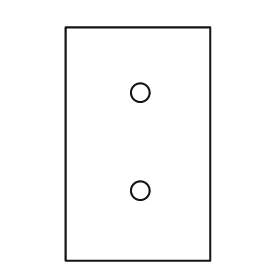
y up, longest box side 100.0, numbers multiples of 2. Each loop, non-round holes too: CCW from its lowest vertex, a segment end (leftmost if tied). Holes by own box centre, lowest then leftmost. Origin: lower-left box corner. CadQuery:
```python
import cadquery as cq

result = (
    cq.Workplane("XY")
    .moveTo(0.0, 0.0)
    .lineTo(62.0, 0.0)
    .lineTo(62.0, 100.0)
    .lineTo(0.0, 100.0)
    .close()
    .moveTo(32.0, 30.0)
    .circle(4.0)
    .moveTo(32.0, 72.0)
    .circle(4.0)
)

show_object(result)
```